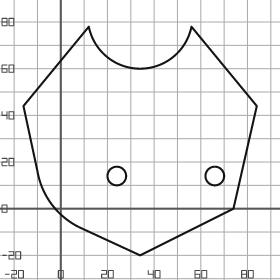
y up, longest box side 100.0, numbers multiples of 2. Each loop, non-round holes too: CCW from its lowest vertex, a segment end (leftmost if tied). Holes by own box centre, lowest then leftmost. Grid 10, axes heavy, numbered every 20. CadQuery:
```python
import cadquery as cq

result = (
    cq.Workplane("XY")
    .moveTo(34.0, -20.0)
    .lineTo(74.0, 0.0)
    .lineTo(84.0, 44.0)
    .lineTo(56.0, 78.0)
    .threePointArc((34.0, 60.0), (12.0, 78.0))
    .lineTo(-16.0, 44.0)
    .lineTo(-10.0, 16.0)
    .threePointArc((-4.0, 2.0), (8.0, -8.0))
    .close()
    .moveTo(24.0, 14.0)
    .circle(4.0)
    .moveTo(66.0, 14.0)
    .circle(4.0)
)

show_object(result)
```